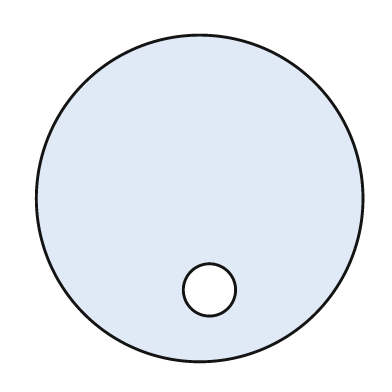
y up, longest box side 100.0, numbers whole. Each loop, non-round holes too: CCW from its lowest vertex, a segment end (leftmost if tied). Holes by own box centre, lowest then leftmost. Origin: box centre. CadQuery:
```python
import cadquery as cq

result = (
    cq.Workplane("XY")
    .moveTo(0.0, 0.0)
    .circle(50.0)
    .moveTo(3.0, -28.0)
    .circle(8.0)
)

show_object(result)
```